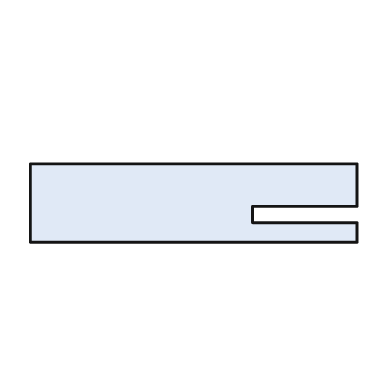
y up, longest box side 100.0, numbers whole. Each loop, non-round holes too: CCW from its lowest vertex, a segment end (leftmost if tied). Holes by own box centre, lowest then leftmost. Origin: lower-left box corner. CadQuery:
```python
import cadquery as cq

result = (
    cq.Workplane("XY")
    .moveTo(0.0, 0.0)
    .lineTo(100.0, 0.0)
    .lineTo(100.0, 6.0)
    .lineTo(68.0, 6.0)
    .lineTo(68.0, 11.0)
    .lineTo(100.0, 11.0)
    .lineTo(100.0, 24.0)
    .lineTo(0.0, 24.0)
    .close()
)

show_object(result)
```